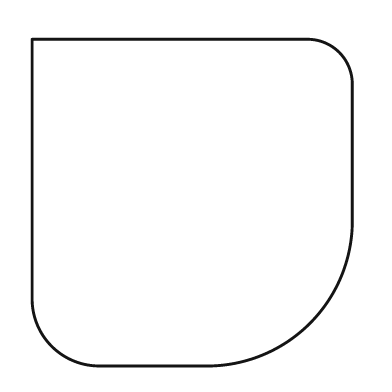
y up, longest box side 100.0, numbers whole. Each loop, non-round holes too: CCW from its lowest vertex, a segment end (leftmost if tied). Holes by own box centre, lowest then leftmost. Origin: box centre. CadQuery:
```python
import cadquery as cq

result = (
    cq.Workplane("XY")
    .moveTo(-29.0, -50.0)
    .lineTo(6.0, -50.0)
    .threePointArc((36.0, -37.0), (49.0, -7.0))
    .lineTo(49.0, 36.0)
    .threePointArc((45.0, 46.0), (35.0, 50.0))
    .lineTo(-49.0, 50.0)
    .lineTo(-49.0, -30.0)
    .threePointArc((-43.0, -44.0), (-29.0, -50.0))
    .close()
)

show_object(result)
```